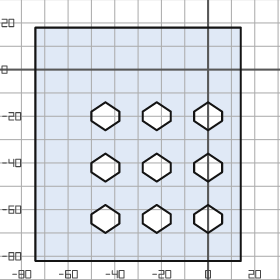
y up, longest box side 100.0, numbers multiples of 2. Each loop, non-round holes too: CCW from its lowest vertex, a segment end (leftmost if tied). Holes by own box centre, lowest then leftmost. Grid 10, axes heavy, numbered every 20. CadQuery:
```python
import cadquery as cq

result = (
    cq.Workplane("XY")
    .moveTo(-74.0, -82.0)
    .lineTo(14.0, -82.0)
    .lineTo(14.0, 18.0)
    .lineTo(-74.0, 18.0)
    .close()
    .moveTo(-44.0, -70.0)
    .lineTo(-38.0, -66.0)
    .lineTo(-38.0, -62.0)
    .lineTo(-44.0, -58.0)
    .lineTo(-50.0, -62.0)
    .lineTo(-50.0, -66.0)
    .close()
    .moveTo(-22.0, -70.0)
    .lineTo(-16.0, -66.0)
    .lineTo(-16.0, -62.0)
    .lineTo(-22.0, -58.0)
    .lineTo(-28.0, -62.0)
    .lineTo(-28.0, -66.0)
    .close()
    .moveTo(0.0, -70.0)
    .lineTo(6.0, -66.0)
    .lineTo(6.0, -62.0)
    .lineTo(0.0, -58.0)
    .lineTo(-6.0, -62.0)
    .lineTo(-6.0, -66.0)
    .close()
    .moveTo(-44.0, -48.0)
    .lineTo(-38.0, -44.0)
    .lineTo(-38.0, -40.0)
    .lineTo(-44.0, -36.0)
    .lineTo(-50.0, -40.0)
    .lineTo(-50.0, -44.0)
    .close()
    .moveTo(-22.0, -48.0)
    .lineTo(-16.0, -44.0)
    .lineTo(-16.0, -40.0)
    .lineTo(-22.0, -36.0)
    .lineTo(-28.0, -40.0)
    .lineTo(-28.0, -44.0)
    .close()
    .moveTo(0.0, -48.0)
    .lineTo(6.0, -44.0)
    .lineTo(6.0, -40.0)
    .lineTo(0.0, -36.0)
    .lineTo(-6.0, -40.0)
    .lineTo(-6.0, -44.0)
    .close()
    .moveTo(-44.0, -26.0)
    .lineTo(-38.0, -22.0)
    .lineTo(-38.0, -18.0)
    .lineTo(-44.0, -14.0)
    .lineTo(-50.0, -18.0)
    .lineTo(-50.0, -22.0)
    .close()
    .moveTo(-22.0, -26.0)
    .lineTo(-16.0, -22.0)
    .lineTo(-16.0, -18.0)
    .lineTo(-22.0, -14.0)
    .lineTo(-28.0, -18.0)
    .lineTo(-28.0, -22.0)
    .close()
    .moveTo(0.0, -26.0)
    .lineTo(6.0, -22.0)
    .lineTo(6.0, -18.0)
    .lineTo(0.0, -14.0)
    .lineTo(-6.0, -18.0)
    .lineTo(-6.0, -22.0)
    .close()
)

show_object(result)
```